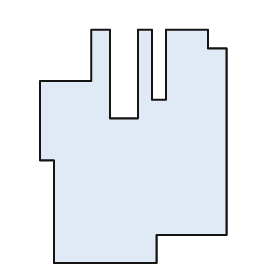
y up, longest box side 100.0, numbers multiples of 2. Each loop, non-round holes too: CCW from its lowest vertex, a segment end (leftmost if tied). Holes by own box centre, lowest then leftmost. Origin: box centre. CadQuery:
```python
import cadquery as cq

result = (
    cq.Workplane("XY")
    .moveTo(-34.0, -50.0)
    .lineTo(10.0, -50.0)
    .lineTo(10.0, -38.0)
    .lineTo(40.0, -38.0)
    .lineTo(40.0, 42.0)
    .lineTo(32.0, 42.0)
    .lineTo(32.0, 50.0)
    .lineTo(14.0, 50.0)
    .lineTo(14.0, 20.0)
    .lineTo(8.0, 20.0)
    .lineTo(8.0, 50.0)
    .lineTo(2.0, 50.0)
    .lineTo(2.0, 12.0)
    .lineTo(-10.0, 12.0)
    .lineTo(-10.0, 50.0)
    .lineTo(-18.0, 50.0)
    .lineTo(-18.0, 28.0)
    .lineTo(-40.0, 28.0)
    .lineTo(-40.0, -6.0)
    .lineTo(-34.0, -6.0)
    .close()
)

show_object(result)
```